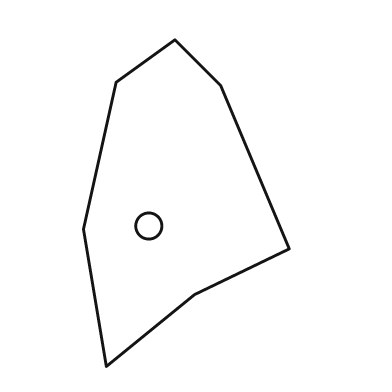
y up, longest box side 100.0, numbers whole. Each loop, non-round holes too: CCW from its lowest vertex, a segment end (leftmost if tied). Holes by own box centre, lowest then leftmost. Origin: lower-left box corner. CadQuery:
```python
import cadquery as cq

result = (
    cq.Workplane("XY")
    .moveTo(7.0, 0.0)
    .lineTo(34.0, 22.0)
    .lineTo(63.0, 36.0)
    .lineTo(42.0, 86.0)
    .lineTo(28.0, 100.0)
    .lineTo(10.0, 87.0)
    .lineTo(0.0, 42.0)
    .close()
    .moveTo(20.0, 43.0)
    .circle(4.0)
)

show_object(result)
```